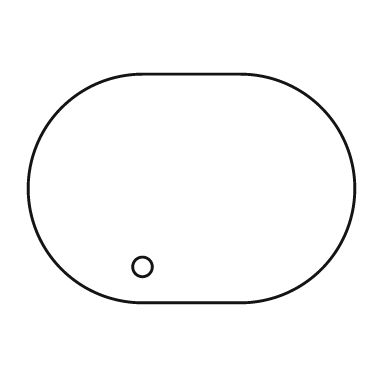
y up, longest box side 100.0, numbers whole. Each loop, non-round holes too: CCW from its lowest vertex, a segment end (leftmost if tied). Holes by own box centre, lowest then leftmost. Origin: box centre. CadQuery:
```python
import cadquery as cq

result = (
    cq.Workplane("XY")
    .moveTo(-15.0, -35.0)
    .lineTo(15.0, -35.0)
    .threePointArc((50.0, 0.0), (15.0, 35.0))
    .lineTo(-15.0, 35.0)
    .threePointArc((-50.0, 0.0), (-15.0, -35.0))
    .close()
    .moveTo(-15.0, -24.0)
    .circle(3.0)
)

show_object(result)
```